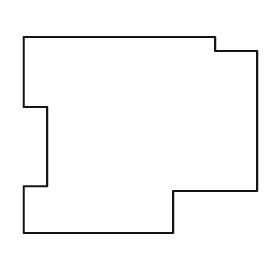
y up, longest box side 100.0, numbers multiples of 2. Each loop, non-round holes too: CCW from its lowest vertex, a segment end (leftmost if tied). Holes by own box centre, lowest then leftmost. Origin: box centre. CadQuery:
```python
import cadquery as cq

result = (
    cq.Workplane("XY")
    .moveTo(-50.0, -42.0)
    .lineTo(14.0, -42.0)
    .lineTo(14.0, -24.0)
    .lineTo(50.0, -24.0)
    .lineTo(50.0, 36.0)
    .lineTo(32.0, 36.0)
    .lineTo(32.0, 42.0)
    .lineTo(-50.0, 42.0)
    .lineTo(-50.0, 12.0)
    .lineTo(-40.0, 12.0)
    .lineTo(-40.0, -22.0)
    .lineTo(-50.0, -22.0)
    .close()
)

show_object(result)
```